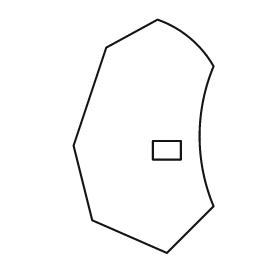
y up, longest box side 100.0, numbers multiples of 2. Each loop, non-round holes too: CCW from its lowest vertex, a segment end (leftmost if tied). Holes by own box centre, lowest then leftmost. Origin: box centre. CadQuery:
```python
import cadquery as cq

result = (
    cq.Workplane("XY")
    .moveTo(10.0, -50.0)
    .lineTo(30.0, -30.0)
    .threePointArc((24.0, 0.0), (30.0, 30.0))
    .threePointArc((20.0, 42.0), (6.0, 50.0))
    .lineTo(-16.0, 38.0)
    .lineTo(-30.0, -4.0)
    .lineTo(-22.0, -36.0)
    .close()
    .moveTo(4.0, -10.0)
    .lineTo(16.0, -10.0)
    .lineTo(16.0, -2.0)
    .lineTo(4.0, -2.0)
    .close()
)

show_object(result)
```